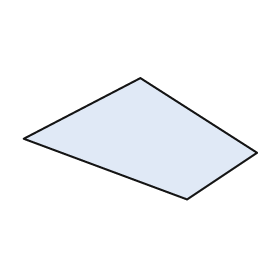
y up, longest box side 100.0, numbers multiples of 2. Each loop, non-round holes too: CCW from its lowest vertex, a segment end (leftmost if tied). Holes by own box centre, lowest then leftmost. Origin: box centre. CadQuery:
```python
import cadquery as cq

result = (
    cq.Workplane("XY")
    .moveTo(20.0, -26.0)
    .lineTo(50.0, -6.0)
    .lineTo(0.0, 26.0)
    .lineTo(-50.0, 0.0)
    .close()
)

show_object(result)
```